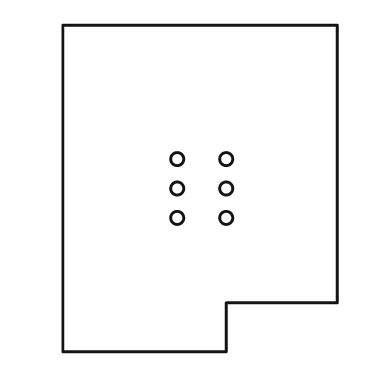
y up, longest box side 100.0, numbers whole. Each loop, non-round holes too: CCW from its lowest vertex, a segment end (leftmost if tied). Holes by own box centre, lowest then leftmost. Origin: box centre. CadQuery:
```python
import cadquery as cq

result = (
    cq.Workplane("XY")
    .moveTo(-42.0, -50.0)
    .lineTo(8.0, -50.0)
    .lineTo(8.0, -35.0)
    .lineTo(42.0, -35.0)
    .lineTo(42.0, 50.0)
    .lineTo(-42.0, 50.0)
    .close()
    .moveTo(-7.0, -9.0)
    .circle(2.0)
    .moveTo(8.0, -9.0)
    .circle(2.0)
    .moveTo(-7.0, 0.0)
    .circle(2.0)
    .moveTo(8.0, 0.0)
    .circle(2.0)
    .moveTo(-7.0, 9.0)
    .circle(2.0)
    .moveTo(8.0, 9.0)
    .circle(2.0)
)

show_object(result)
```